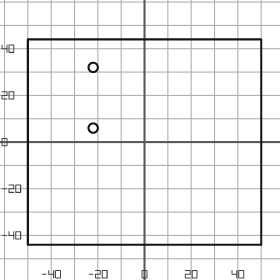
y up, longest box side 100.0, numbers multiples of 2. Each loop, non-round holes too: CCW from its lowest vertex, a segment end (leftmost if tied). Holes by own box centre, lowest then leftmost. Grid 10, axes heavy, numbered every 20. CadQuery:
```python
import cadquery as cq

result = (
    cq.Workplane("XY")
    .moveTo(-50.0, -44.0)
    .lineTo(50.0, -44.0)
    .lineTo(50.0, 44.0)
    .lineTo(-50.0, 44.0)
    .close()
    .moveTo(-22.0, 6.0)
    .circle(2.0)
    .moveTo(-22.0, 32.0)
    .circle(2.0)
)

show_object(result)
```